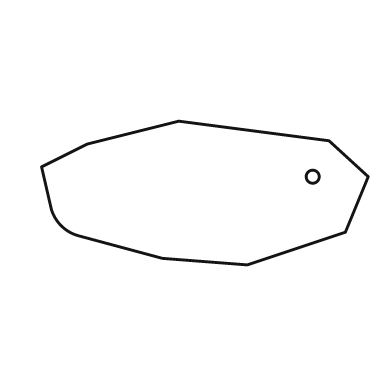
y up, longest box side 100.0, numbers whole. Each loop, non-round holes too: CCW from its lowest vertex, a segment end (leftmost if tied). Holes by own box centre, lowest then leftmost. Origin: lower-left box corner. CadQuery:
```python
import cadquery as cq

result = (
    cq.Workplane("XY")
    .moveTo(63.0, 0.0)
    .lineTo(93.0, 10.0)
    .lineTo(100.0, 27.0)
    .lineTo(88.0, 38.0)
    .lineTo(42.0, 44.0)
    .lineTo(14.0, 37.0)
    .lineTo(0.0, 30.0)
    .lineTo(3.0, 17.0)
    .threePointArc((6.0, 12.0), (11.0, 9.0))
    .lineTo(37.0, 2.0)
    .close()
    .moveTo(83.0, 27.0)
    .circle(2.0)
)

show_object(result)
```